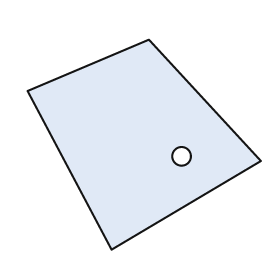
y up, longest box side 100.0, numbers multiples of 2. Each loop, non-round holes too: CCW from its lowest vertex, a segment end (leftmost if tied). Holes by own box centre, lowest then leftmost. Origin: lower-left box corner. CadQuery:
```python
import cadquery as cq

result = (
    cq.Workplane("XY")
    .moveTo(36.0, 0.0)
    .lineTo(100.0, 38.0)
    .lineTo(52.0, 90.0)
    .lineTo(0.0, 68.0)
    .close()
    .moveTo(66.0, 40.0)
    .circle(4.0)
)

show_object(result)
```